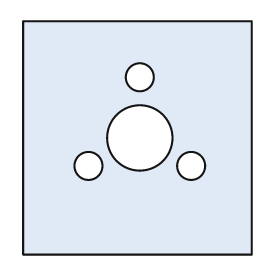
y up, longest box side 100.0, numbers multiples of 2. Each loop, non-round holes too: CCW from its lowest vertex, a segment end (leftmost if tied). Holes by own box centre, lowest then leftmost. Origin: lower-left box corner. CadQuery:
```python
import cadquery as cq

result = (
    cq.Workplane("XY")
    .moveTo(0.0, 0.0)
    .lineTo(98.0, 0.0)
    .lineTo(98.0, 100.0)
    .lineTo(0.0, 100.0)
    .close()
    .moveTo(28.0, 38.0)
    .circle(6.0)
    .moveTo(72.0, 38.0)
    .circle(6.0)
    .moveTo(50.0, 50.0)
    .circle(14.0)
    .moveTo(50.0, 76.0)
    .circle(6.0)
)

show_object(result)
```